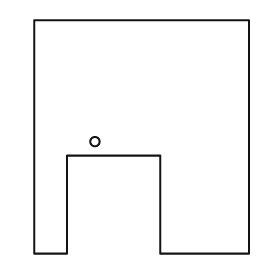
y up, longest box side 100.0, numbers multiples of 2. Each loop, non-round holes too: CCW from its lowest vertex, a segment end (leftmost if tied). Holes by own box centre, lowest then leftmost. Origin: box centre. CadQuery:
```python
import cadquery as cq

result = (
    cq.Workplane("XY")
    .moveTo(-46.0, -50.0)
    .lineTo(-32.0, -50.0)
    .lineTo(-32.0, -8.0)
    .lineTo(8.0, -8.0)
    .lineTo(8.0, -50.0)
    .lineTo(46.0, -50.0)
    .lineTo(46.0, 50.0)
    .lineTo(-46.0, 50.0)
    .close()
    .moveTo(-20.0, -2.0)
    .circle(2.0)
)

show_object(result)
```